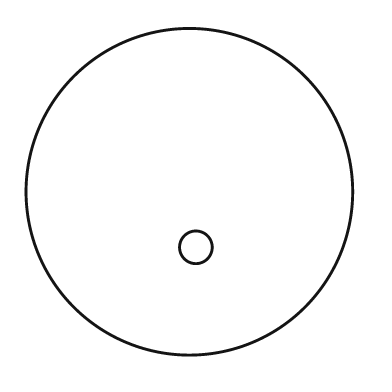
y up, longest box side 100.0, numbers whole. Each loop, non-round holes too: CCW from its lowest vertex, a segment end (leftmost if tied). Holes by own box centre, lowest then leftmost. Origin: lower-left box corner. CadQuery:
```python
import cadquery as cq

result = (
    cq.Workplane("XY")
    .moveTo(50.0, 50.0)
    .circle(50.0)
    .moveTo(52.0, 33.0)
    .circle(5.0)
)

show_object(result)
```